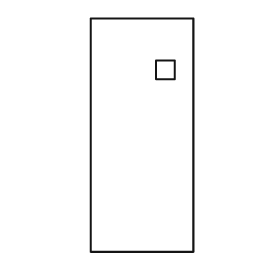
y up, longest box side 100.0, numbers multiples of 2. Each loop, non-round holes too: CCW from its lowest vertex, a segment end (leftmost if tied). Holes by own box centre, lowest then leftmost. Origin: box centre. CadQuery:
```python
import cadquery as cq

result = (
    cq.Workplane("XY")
    .moveTo(-22.0, -50.0)
    .lineTo(22.0, -50.0)
    .lineTo(22.0, 50.0)
    .lineTo(-22.0, 50.0)
    .close()
    .moveTo(6.0, 24.0)
    .lineTo(14.0, 24.0)
    .lineTo(14.0, 32.0)
    .lineTo(6.0, 32.0)
    .close()
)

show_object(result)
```